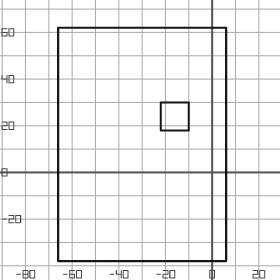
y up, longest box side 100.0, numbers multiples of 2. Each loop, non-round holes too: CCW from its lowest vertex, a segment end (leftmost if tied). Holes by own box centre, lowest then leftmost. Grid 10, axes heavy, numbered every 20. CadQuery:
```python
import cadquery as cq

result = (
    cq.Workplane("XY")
    .moveTo(-66.0, -38.0)
    .lineTo(6.0, -38.0)
    .lineTo(6.0, 62.0)
    .lineTo(-66.0, 62.0)
    .close()
    .moveTo(-22.0, 18.0)
    .lineTo(-10.0, 18.0)
    .lineTo(-10.0, 30.0)
    .lineTo(-22.0, 30.0)
    .close()
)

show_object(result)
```